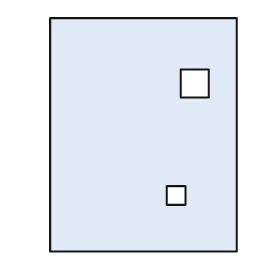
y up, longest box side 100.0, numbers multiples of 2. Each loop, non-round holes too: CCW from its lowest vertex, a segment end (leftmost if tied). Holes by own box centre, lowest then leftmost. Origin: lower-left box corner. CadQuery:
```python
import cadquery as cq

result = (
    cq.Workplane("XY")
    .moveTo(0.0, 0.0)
    .lineTo(80.0, 0.0)
    .lineTo(80.0, 100.0)
    .lineTo(0.0, 100.0)
    .close()
    .moveTo(50.0, 20.0)
    .lineTo(58.0, 20.0)
    .lineTo(58.0, 28.0)
    .lineTo(50.0, 28.0)
    .close()
    .moveTo(56.0, 66.0)
    .lineTo(68.0, 66.0)
    .lineTo(68.0, 78.0)
    .lineTo(56.0, 78.0)
    .close()
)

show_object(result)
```